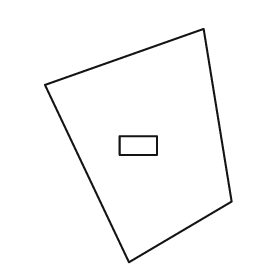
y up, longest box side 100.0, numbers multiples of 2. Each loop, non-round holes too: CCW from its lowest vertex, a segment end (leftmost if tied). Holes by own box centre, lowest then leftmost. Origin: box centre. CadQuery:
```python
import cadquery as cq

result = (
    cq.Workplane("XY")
    .moveTo(-4.0, -50.0)
    .lineTo(40.0, -24.0)
    .lineTo(28.0, 50.0)
    .lineTo(-40.0, 26.0)
    .close()
    .moveTo(-8.0, -4.0)
    .lineTo(8.0, -4.0)
    .lineTo(8.0, 4.0)
    .lineTo(-8.0, 4.0)
    .close()
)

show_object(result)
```